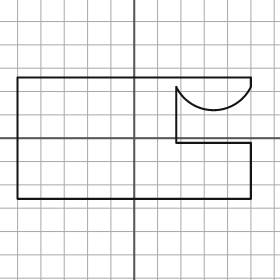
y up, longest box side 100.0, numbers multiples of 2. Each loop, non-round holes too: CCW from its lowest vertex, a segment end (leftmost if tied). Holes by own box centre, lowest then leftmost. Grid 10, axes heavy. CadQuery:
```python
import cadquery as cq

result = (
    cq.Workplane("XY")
    .moveTo(-50.0, -26.0)
    .lineTo(50.0, -26.0)
    .lineTo(50.0, -2.0)
    .lineTo(18.0, -2.0)
    .lineTo(18.0, 22.0)
    .threePointArc((34.0, 12.0), (50.0, 22.0))
    .lineTo(50.0, 26.0)
    .lineTo(-50.0, 26.0)
    .close()
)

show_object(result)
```